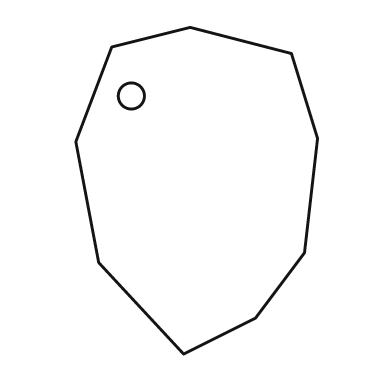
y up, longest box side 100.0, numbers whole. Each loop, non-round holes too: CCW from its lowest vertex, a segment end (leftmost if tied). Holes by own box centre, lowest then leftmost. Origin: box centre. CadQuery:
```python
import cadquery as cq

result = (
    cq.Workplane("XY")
    .moveTo(-4.0, -50.0)
    .lineTo(18.0, -39.0)
    .lineTo(33.0, -19.0)
    .lineTo(37.0, 16.0)
    .lineTo(29.0, 42.0)
    .lineTo(-2.0, 50.0)
    .lineTo(-26.0, 44.0)
    .lineTo(-37.0, 15.0)
    .lineTo(-30.0, -22.0)
    .close()
    .moveTo(-20.0, 29.0)
    .circle(4.0)
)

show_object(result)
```